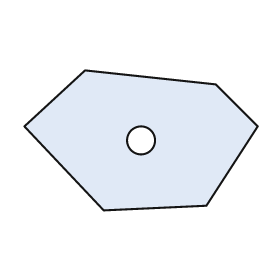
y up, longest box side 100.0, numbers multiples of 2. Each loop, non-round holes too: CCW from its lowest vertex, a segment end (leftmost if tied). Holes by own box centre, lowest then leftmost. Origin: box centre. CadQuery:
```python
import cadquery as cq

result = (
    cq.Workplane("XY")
    .moveTo(-16.0, -30.0)
    .lineTo(28.0, -28.0)
    .lineTo(50.0, 6.0)
    .lineTo(32.0, 24.0)
    .lineTo(-24.0, 30.0)
    .lineTo(-50.0, 6.0)
    .close()
    .moveTo(0.0, 0.0)
    .circle(6.0)
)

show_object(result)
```